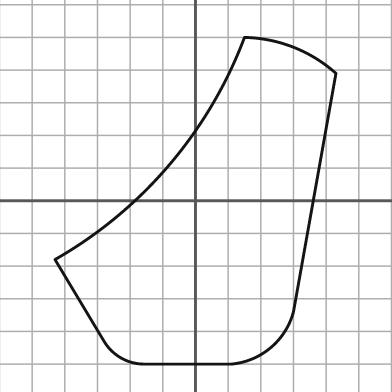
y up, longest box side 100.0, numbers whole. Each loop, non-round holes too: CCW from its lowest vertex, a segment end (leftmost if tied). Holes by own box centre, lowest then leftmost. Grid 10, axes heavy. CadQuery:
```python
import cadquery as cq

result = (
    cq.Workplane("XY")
    .moveTo(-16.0, -50.0)
    .lineTo(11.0, -50.0)
    .threePointArc((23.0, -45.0), (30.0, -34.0))
    .lineTo(43.0, 39.0)
    .threePointArc((30.0, 47.0), (15.0, 50.0))
    .threePointArc((-8.0, 11.0), (-43.0, -18.0))
    .lineTo(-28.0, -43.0)
    .threePointArc((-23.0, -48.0), (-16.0, -50.0))
    .close()
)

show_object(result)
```